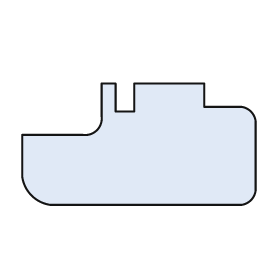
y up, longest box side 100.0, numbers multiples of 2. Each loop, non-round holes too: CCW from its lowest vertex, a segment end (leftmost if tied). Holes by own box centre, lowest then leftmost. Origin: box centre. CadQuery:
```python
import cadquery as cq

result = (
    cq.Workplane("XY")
    .moveTo(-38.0, -26.0)
    .lineTo(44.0, -26.0)
    .threePointArc((48.0, -24.0), (50.0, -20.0))
    .lineTo(50.0, 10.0)
    .threePointArc((48.0, 14.0), (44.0, 16.0))
    .lineTo(28.0, 16.0)
    .lineTo(28.0, 26.0)
    .lineTo(-2.0, 26.0)
    .lineTo(-2.0, 14.0)
    .lineTo(-10.0, 14.0)
    .lineTo(-10.0, 26.0)
    .lineTo(-16.0, 26.0)
    .lineTo(-16.0, 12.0)
    .threePointArc((-18.0, 6.0), (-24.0, 4.0))
    .lineTo(-50.0, 4.0)
    .lineTo(-50.0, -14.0)
    .threePointArc((-46.0, -22.0), (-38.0, -26.0))
    .close()
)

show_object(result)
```